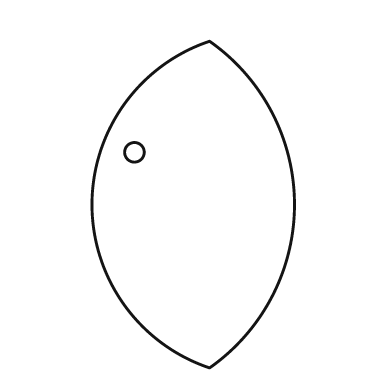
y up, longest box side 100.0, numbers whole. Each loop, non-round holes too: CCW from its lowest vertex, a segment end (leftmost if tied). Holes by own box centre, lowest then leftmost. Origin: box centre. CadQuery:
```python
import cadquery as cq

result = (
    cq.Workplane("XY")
    .moveTo(5.0, -50.0)
    .threePointArc((31.0, 0.0), (5.0, 50.0))
    .threePointArc((-31.0, 0.0), (5.0, -50.0))
    .close()
    .moveTo(-18.0, 16.0)
    .circle(3.0)
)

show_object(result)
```